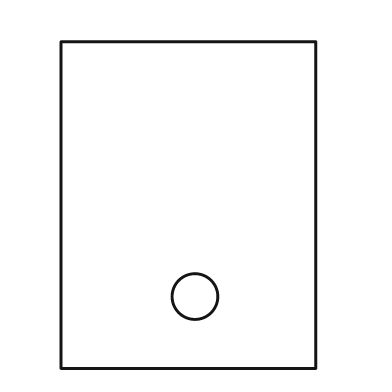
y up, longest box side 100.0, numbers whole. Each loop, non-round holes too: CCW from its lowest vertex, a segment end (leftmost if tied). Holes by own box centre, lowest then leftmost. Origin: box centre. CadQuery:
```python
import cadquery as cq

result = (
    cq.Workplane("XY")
    .moveTo(-39.0, -50.0)
    .lineTo(39.0, -50.0)
    .lineTo(39.0, 50.0)
    .lineTo(-39.0, 50.0)
    .close()
    .moveTo(2.0, -28.0)
    .circle(7.0)
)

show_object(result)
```